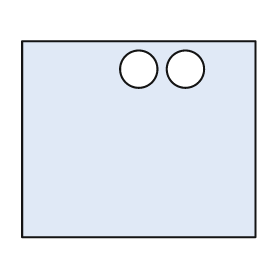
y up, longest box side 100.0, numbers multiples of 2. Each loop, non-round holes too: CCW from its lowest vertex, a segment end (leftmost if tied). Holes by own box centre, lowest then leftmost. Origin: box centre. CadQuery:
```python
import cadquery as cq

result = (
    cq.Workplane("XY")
    .moveTo(-50.0, -42.0)
    .lineTo(50.0, -42.0)
    .lineTo(50.0, 42.0)
    .lineTo(-50.0, 42.0)
    .close()
    .moveTo(0.0, 30.0)
    .circle(8.0)
    .moveTo(20.0, 30.0)
    .circle(8.0)
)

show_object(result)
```